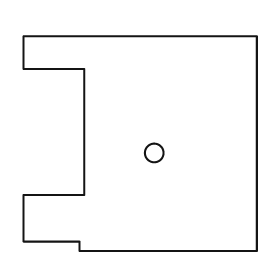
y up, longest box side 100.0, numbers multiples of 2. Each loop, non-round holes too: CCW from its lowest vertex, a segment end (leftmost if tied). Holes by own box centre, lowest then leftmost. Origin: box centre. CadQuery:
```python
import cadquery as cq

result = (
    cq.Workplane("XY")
    .moveTo(-26.0, -46.0)
    .lineTo(50.0, -46.0)
    .lineTo(50.0, 46.0)
    .lineTo(-50.0, 46.0)
    .lineTo(-50.0, 32.0)
    .lineTo(-24.0, 32.0)
    .lineTo(-24.0, -22.0)
    .lineTo(-50.0, -22.0)
    .lineTo(-50.0, -42.0)
    .lineTo(-26.0, -42.0)
    .close()
    .moveTo(6.0, -4.0)
    .circle(4.0)
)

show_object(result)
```